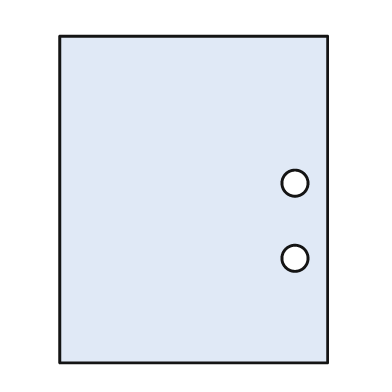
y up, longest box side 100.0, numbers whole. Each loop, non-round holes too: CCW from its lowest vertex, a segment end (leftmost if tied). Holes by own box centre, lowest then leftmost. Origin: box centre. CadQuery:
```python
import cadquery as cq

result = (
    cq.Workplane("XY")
    .moveTo(-41.0, -50.0)
    .lineTo(41.0, -50.0)
    .lineTo(41.0, 50.0)
    .lineTo(-41.0, 50.0)
    .close()
    .moveTo(31.0, -18.0)
    .circle(4.0)
    .moveTo(31.0, 5.0)
    .circle(4.0)
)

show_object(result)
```